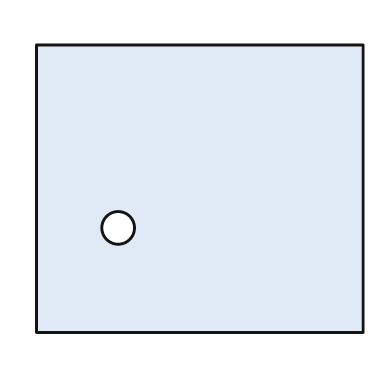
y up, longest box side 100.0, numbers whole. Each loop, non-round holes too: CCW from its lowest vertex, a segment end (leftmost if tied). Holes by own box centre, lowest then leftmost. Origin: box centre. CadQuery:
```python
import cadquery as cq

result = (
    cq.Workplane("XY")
    .moveTo(-50.0, -44.0)
    .lineTo(50.0, -44.0)
    .lineTo(50.0, 44.0)
    .lineTo(-50.0, 44.0)
    .close()
    .moveTo(-25.0, -12.0)
    .circle(5.0)
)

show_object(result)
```